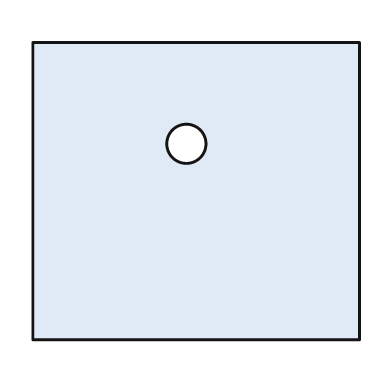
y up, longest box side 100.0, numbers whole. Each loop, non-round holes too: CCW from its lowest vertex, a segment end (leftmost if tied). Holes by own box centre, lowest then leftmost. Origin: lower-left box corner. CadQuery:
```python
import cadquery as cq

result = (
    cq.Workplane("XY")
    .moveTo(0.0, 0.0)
    .lineTo(100.0, 0.0)
    .lineTo(100.0, 91.0)
    .lineTo(0.0, 91.0)
    .close()
    .moveTo(47.0, 60.0)
    .circle(6.0)
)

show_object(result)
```